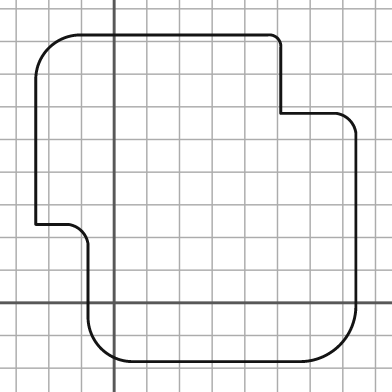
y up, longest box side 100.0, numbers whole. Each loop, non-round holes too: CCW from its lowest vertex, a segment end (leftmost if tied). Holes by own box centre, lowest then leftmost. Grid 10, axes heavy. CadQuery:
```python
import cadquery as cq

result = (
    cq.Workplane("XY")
    .moveTo(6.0, -18.0)
    .lineTo(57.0, -18.0)
    .threePointArc((69.0, -13.0), (74.0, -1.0))
    .lineTo(74.0, 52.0)
    .threePointArc((72.0, 56.0), (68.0, 58.0))
    .lineTo(51.0, 58.0)
    .lineTo(51.0, 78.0)
    .threePointArc((50.0, 81.0), (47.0, 82.0))
    .lineTo(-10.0, 82.0)
    .threePointArc((-20.0, 78.0), (-24.0, 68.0))
    .lineTo(-24.0, 24.0)
    .lineTo(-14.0, 24.0)
    .threePointArc((-10.0, 22.0), (-8.0, 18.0))
    .lineTo(-8.0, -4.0)
    .threePointArc((-4.0, -14.0), (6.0, -18.0))
    .close()
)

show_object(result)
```